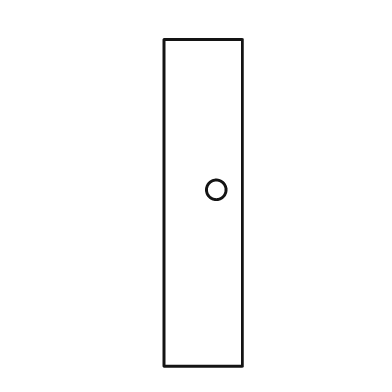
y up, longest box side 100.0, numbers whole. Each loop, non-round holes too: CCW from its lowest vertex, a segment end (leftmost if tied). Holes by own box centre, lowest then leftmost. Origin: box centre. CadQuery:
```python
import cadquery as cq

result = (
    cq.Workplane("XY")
    .moveTo(-12.0, -50.0)
    .lineTo(12.0, -50.0)
    .lineTo(12.0, 50.0)
    .lineTo(-12.0, 50.0)
    .close()
    .moveTo(4.0, 4.0)
    .circle(3.0)
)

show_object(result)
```